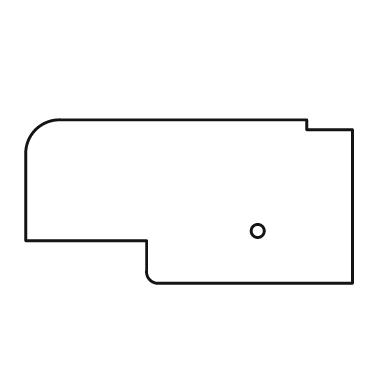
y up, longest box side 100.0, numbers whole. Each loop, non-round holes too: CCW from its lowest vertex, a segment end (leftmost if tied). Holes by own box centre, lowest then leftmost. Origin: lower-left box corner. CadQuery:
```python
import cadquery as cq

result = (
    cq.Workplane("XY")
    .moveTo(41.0, 0.0)
    .lineTo(100.0, 0.0)
    .lineTo(100.0, 47.0)
    .lineTo(86.0, 47.0)
    .lineTo(86.0, 50.0)
    .lineTo(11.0, 50.0)
    .threePointArc((3.0, 47.0), (0.0, 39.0))
    .lineTo(0.0, 13.0)
    .lineTo(37.0, 13.0)
    .lineTo(37.0, 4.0)
    .threePointArc((38.0, 1.0), (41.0, 0.0))
    .close()
    .moveTo(71.0, 16.0)
    .circle(2.0)
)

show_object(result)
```